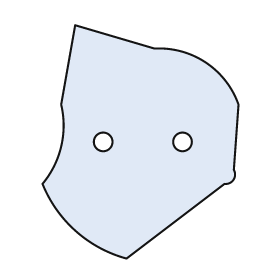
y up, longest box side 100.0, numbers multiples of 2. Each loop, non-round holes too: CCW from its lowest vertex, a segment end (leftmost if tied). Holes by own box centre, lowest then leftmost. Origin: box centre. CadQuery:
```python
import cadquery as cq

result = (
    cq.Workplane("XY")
    .moveTo(-6.0, -50.0)
    .lineTo(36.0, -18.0)
    .threePointArc((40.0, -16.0), (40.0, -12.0))
    .lineTo(42.0, 16.0)
    .threePointArc((28.0, 34.0), (6.0, 40.0))
    .lineTo(-28.0, 50.0)
    .lineTo(-34.0, 16.0)
    .threePointArc((-34.0, -2.0), (-42.0, -18.0))
    .threePointArc((-28.0, -38.0), (-6.0, -50.0))
    .close()
    .moveTo(-16.0, 0.0)
    .circle(4.0)
    .moveTo(18.0, 0.0)
    .circle(4.0)
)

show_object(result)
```